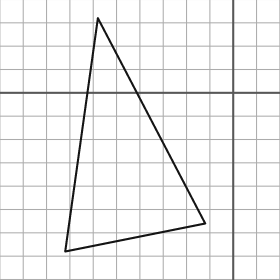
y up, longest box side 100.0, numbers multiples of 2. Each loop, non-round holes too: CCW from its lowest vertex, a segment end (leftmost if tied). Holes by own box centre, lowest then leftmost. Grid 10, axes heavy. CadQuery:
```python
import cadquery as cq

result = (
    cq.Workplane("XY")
    .moveTo(-72.0, -68.0)
    .lineTo(-12.0, -56.0)
    .lineTo(-58.0, 32.0)
    .close()
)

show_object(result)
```